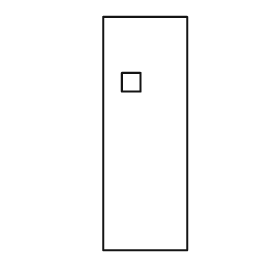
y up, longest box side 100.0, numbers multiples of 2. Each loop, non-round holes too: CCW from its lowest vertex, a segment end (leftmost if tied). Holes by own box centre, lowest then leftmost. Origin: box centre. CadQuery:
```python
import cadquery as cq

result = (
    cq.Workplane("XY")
    .moveTo(-18.0, -50.0)
    .lineTo(18.0, -50.0)
    .lineTo(18.0, 50.0)
    .lineTo(-18.0, 50.0)
    .close()
    .moveTo(-10.0, 18.0)
    .lineTo(-2.0, 18.0)
    .lineTo(-2.0, 26.0)
    .lineTo(-10.0, 26.0)
    .close()
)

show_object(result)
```